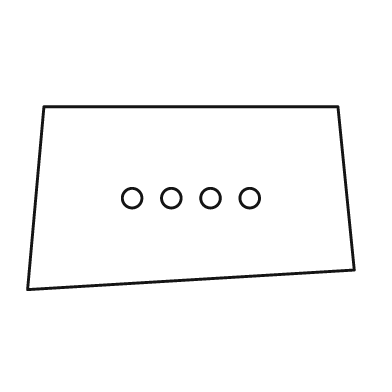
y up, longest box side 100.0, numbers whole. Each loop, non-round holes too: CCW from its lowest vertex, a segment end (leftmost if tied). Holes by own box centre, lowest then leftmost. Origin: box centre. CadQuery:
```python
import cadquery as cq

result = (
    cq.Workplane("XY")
    .moveTo(-50.0, -28.0)
    .lineTo(50.0, -22.0)
    .lineTo(45.0, 28.0)
    .lineTo(-45.0, 28.0)
    .close()
    .moveTo(-18.0, 0.0)
    .circle(3.0)
    .moveTo(-6.0, 0.0)
    .circle(3.0)
    .moveTo(6.0, 0.0)
    .circle(3.0)
    .moveTo(18.0, 0.0)
    .circle(3.0)
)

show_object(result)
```